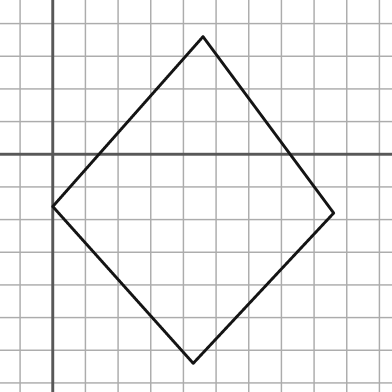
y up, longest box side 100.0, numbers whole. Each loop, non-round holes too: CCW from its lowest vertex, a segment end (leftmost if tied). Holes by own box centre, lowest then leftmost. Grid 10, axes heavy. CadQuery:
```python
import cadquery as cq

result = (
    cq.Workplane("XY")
    .moveTo(43.0, -64.0)
    .lineTo(86.0, -18.0)
    .lineTo(46.0, 36.0)
    .lineTo(0.0, -16.0)
    .close()
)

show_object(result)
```